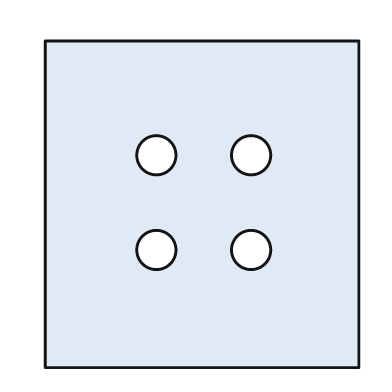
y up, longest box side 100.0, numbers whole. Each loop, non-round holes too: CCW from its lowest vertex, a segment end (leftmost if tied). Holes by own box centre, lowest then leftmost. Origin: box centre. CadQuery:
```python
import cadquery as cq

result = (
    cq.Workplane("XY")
    .moveTo(-48.0, -50.0)
    .lineTo(48.0, -50.0)
    .lineTo(48.0, 50.0)
    .lineTo(-48.0, 50.0)
    .close()
    .moveTo(-14.0, -14.0)
    .circle(6.0)
    .moveTo(15.0, -14.0)
    .circle(6.0)
    .moveTo(-14.0, 15.0)
    .circle(6.0)
    .moveTo(15.0, 15.0)
    .circle(6.0)
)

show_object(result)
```